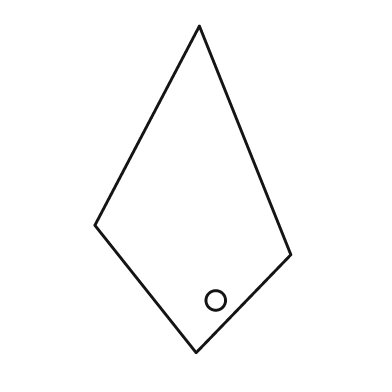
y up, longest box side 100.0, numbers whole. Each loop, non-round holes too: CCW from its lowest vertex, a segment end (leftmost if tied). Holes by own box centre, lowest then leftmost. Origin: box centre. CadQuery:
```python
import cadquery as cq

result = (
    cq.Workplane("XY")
    .moveTo(1.0, -50.0)
    .lineTo(30.0, -20.0)
    .lineTo(2.0, 50.0)
    .lineTo(-30.0, -11.0)
    .close()
    .moveTo(7.0, -34.0)
    .circle(3.0)
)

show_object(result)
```